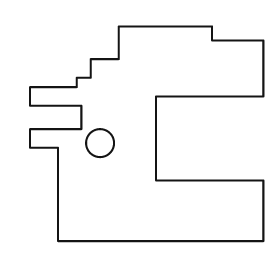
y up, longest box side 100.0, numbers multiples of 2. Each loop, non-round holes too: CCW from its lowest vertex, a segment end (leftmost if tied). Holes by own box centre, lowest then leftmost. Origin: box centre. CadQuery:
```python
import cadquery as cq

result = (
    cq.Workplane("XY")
    .moveTo(-38.0, -46.0)
    .lineTo(50.0, -46.0)
    .lineTo(50.0, -20.0)
    .lineTo(4.0, -20.0)
    .lineTo(4.0, 16.0)
    .lineTo(50.0, 16.0)
    .lineTo(50.0, 40.0)
    .lineTo(28.0, 40.0)
    .lineTo(28.0, 46.0)
    .lineTo(-12.0, 46.0)
    .lineTo(-12.0, 32.0)
    .lineTo(-24.0, 32.0)
    .lineTo(-24.0, 24.0)
    .lineTo(-30.0, 24.0)
    .lineTo(-30.0, 20.0)
    .lineTo(-50.0, 20.0)
    .lineTo(-50.0, 12.0)
    .lineTo(-28.0, 12.0)
    .lineTo(-28.0, 2.0)
    .lineTo(-50.0, 2.0)
    .lineTo(-50.0, -6.0)
    .lineTo(-38.0, -6.0)
    .close()
    .moveTo(-20.0, -4.0)
    .circle(6.0)
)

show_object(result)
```